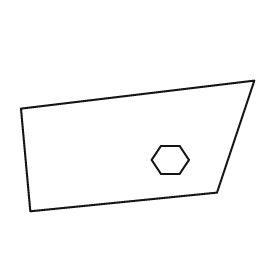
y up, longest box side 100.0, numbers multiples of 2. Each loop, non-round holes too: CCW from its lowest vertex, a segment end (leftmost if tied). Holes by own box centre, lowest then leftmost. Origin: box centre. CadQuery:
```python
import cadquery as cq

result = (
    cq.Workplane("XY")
    .moveTo(-46.0, -28.0)
    .lineTo(34.0, -20.0)
    .lineTo(50.0, 28.0)
    .lineTo(-50.0, 16.0)
    .close()
    .moveTo(10.0, -12.0)
    .lineTo(18.0, -12.0)
    .lineTo(22.0, -6.0)
    .lineTo(18.0, 0.0)
    .lineTo(10.0, 0.0)
    .lineTo(6.0, -6.0)
    .close()
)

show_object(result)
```